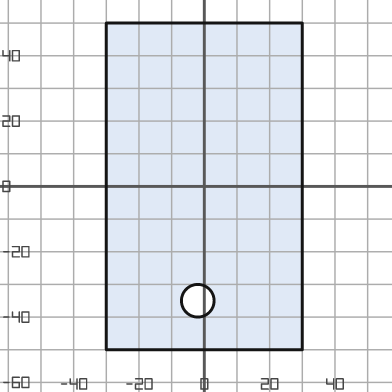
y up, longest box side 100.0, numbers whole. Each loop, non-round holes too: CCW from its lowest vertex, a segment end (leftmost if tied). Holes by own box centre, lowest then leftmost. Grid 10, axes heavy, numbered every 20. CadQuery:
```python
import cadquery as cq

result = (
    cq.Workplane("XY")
    .moveTo(-30.0, -50.0)
    .lineTo(30.0, -50.0)
    .lineTo(30.0, 50.0)
    .lineTo(-30.0, 50.0)
    .close()
    .moveTo(-2.0, -35.0)
    .circle(5.0)
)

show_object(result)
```